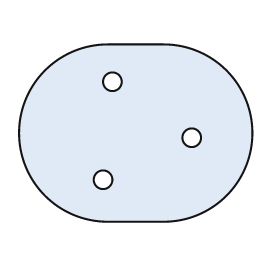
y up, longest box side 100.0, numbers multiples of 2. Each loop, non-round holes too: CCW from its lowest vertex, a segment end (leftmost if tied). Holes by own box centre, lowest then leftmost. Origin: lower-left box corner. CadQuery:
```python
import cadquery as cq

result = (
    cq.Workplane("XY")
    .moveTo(38.0, 0.0)
    .lineTo(62.0, 0.0)
    .threePointArc((100.0, 38.0), (62.0, 76.0))
    .lineTo(38.0, 76.0)
    .threePointArc((0.0, 38.0), (38.0, 0.0))
    .close()
    .moveTo(36.0, 18.0)
    .circle(4.0)
    .moveTo(74.0, 36.0)
    .circle(4.0)
    .moveTo(40.0, 60.0)
    .circle(4.0)
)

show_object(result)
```